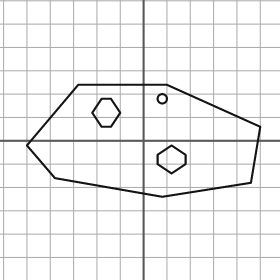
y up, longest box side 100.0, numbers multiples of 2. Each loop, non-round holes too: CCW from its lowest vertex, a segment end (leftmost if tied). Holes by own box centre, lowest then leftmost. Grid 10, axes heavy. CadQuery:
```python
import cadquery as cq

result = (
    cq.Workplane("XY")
    .moveTo(8.0, -24.0)
    .lineTo(46.0, -18.0)
    .lineTo(50.0, 6.0)
    .lineTo(10.0, 24.0)
    .lineTo(-28.0, 24.0)
    .lineTo(-50.0, -2.0)
    .lineTo(-38.0, -16.0)
    .close()
    .moveTo(12.0, -14.0)
    .lineTo(18.0, -10.0)
    .lineTo(18.0, -6.0)
    .lineTo(12.0, -2.0)
    .lineTo(6.0, -6.0)
    .lineTo(6.0, -10.0)
    .close()
    .moveTo(-18.0, 6.0)
    .lineTo(-14.0, 6.0)
    .lineTo(-10.0, 12.0)
    .lineTo(-14.0, 18.0)
    .lineTo(-18.0, 18.0)
    .lineTo(-22.0, 12.0)
    .close()
    .moveTo(8.0, 18.0)
    .circle(2.0)
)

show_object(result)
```